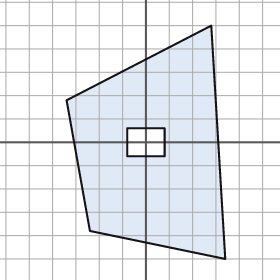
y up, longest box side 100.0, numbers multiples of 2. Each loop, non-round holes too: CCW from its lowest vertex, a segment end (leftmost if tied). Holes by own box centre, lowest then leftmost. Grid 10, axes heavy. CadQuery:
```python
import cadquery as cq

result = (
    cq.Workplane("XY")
    .moveTo(34.0, -50.0)
    .lineTo(28.0, 50.0)
    .lineTo(-34.0, 18.0)
    .lineTo(-24.0, -38.0)
    .close()
    .moveTo(-8.0, -6.0)
    .lineTo(8.0, -6.0)
    .lineTo(8.0, 6.0)
    .lineTo(-8.0, 6.0)
    .close()
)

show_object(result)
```